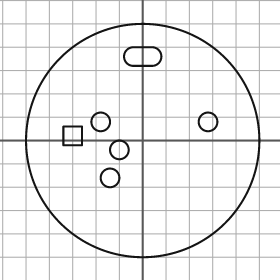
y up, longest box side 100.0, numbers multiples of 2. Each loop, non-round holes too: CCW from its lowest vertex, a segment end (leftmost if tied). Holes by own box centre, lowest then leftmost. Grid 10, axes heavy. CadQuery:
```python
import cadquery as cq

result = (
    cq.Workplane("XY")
    .moveTo(0.0, 0.0)
    .circle(50.0)
    .moveTo(-14.0, -16.0)
    .circle(4.0)
    .moveTo(-10.0, -4.0)
    .circle(4.0)
    .moveTo(-34.0, -2.0)
    .lineTo(-26.0, -2.0)
    .lineTo(-26.0, 6.0)
    .lineTo(-34.0, 6.0)
    .close()
    .moveTo(-18.0, 8.0)
    .circle(4.0)
    .moveTo(28.0, 8.0)
    .circle(4.0)
    .moveTo(-4.0, 32.0)
    .lineTo(4.0, 32.0)
    .threePointArc((8.0, 36.0), (4.0, 40.0))
    .lineTo(-4.0, 40.0)
    .threePointArc((-8.0, 36.0), (-4.0, 32.0))
    .close()
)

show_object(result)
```